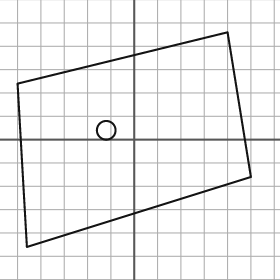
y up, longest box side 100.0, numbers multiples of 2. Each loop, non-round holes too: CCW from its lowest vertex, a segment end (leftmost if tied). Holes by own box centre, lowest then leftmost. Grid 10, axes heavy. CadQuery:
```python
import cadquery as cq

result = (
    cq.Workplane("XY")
    .moveTo(-46.0, -46.0)
    .lineTo(50.0, -16.0)
    .lineTo(40.0, 46.0)
    .lineTo(-50.0, 24.0)
    .close()
    .moveTo(-12.0, 4.0)
    .circle(4.0)
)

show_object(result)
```